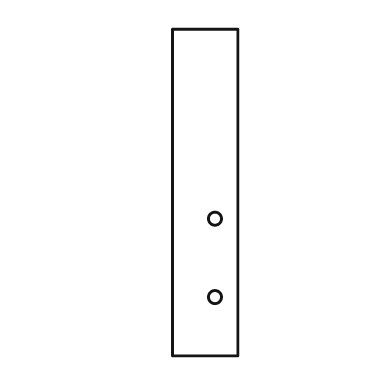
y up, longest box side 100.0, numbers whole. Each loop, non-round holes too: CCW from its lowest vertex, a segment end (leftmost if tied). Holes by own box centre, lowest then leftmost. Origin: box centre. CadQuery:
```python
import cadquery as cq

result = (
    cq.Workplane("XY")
    .moveTo(-10.0, -50.0)
    .lineTo(10.0, -50.0)
    .lineTo(10.0, 50.0)
    .lineTo(-10.0, 50.0)
    .close()
    .moveTo(3.0, -32.0)
    .circle(2.0)
    .moveTo(3.0, -8.0)
    .circle(2.0)
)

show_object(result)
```